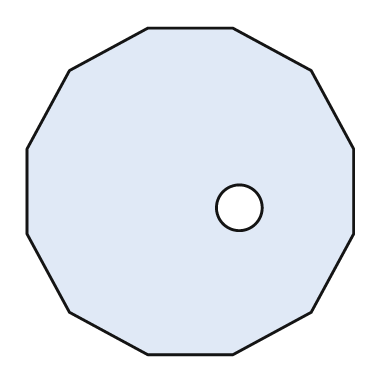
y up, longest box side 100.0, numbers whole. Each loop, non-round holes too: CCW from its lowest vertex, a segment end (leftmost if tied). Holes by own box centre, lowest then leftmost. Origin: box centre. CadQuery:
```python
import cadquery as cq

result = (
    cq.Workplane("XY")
    .moveTo(-13.0, -50.0)
    .lineTo(13.0, -50.0)
    .lineTo(37.0, -37.0)
    .lineTo(50.0, -13.0)
    .lineTo(50.0, 13.0)
    .lineTo(37.0, 37.0)
    .lineTo(13.0, 50.0)
    .lineTo(-13.0, 50.0)
    .lineTo(-37.0, 37.0)
    .lineTo(-50.0, 13.0)
    .lineTo(-50.0, -13.0)
    .lineTo(-37.0, -37.0)
    .close()
    .moveTo(15.0, -5.0)
    .circle(7.0)
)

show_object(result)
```